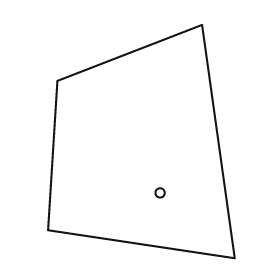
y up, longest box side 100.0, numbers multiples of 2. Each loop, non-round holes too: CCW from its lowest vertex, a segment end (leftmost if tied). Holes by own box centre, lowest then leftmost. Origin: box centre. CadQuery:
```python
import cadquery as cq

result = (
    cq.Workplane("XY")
    .moveTo(40.0, -50.0)
    .lineTo(26.0, 50.0)
    .lineTo(-36.0, 26.0)
    .lineTo(-40.0, -38.0)
    .close()
    .moveTo(8.0, -22.0)
    .circle(2.0)
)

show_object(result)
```